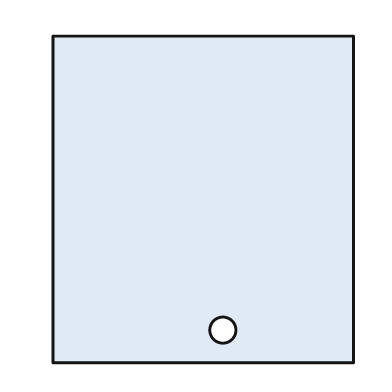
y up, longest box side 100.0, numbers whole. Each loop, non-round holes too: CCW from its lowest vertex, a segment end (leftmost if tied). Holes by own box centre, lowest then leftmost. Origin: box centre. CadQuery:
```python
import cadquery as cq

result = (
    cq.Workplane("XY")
    .moveTo(-46.0, -50.0)
    .lineTo(46.0, -50.0)
    .lineTo(46.0, 50.0)
    .lineTo(-46.0, 50.0)
    .close()
    .moveTo(6.0, -40.0)
    .circle(4.0)
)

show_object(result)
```